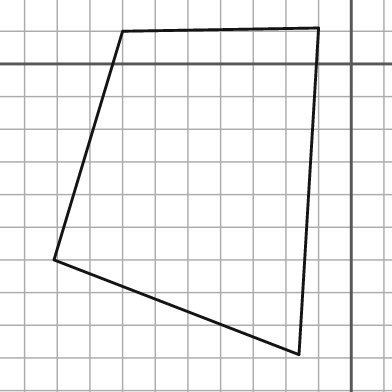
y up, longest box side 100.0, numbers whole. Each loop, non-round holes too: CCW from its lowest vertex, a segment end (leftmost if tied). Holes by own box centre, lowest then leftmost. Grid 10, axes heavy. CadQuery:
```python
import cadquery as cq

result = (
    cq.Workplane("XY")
    .moveTo(-16.0, -89.0)
    .lineTo(-10.0, 11.0)
    .lineTo(-70.0, 10.0)
    .lineTo(-91.0, -60.0)
    .close()
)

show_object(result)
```